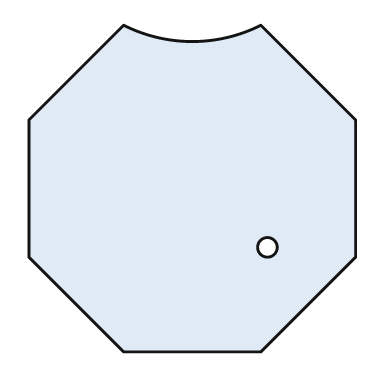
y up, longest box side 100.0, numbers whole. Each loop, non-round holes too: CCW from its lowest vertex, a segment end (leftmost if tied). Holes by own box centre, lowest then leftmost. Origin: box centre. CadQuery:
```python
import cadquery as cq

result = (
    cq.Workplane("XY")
    .moveTo(-21.0, -50.0)
    .lineTo(21.0, -50.0)
    .lineTo(50.0, -21.0)
    .lineTo(50.0, 21.0)
    .lineTo(21.0, 50.0)
    .threePointArc((0.0, 45.0), (-21.0, 50.0))
    .lineTo(-50.0, 21.0)
    .lineTo(-50.0, -21.0)
    .close()
    .moveTo(23.0, -18.0)
    .circle(3.0)
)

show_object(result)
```